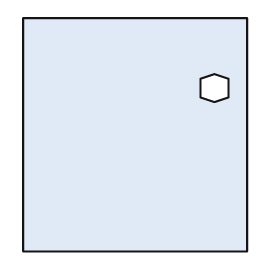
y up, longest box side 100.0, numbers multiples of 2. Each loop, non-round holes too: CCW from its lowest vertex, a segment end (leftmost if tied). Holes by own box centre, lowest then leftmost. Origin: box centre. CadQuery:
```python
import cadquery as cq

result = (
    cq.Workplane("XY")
    .moveTo(-48.0, -50.0)
    .lineTo(48.0, -50.0)
    .lineTo(48.0, 50.0)
    .lineTo(-48.0, 50.0)
    .close()
    .moveTo(34.0, 14.0)
    .lineTo(40.0, 16.0)
    .lineTo(40.0, 24.0)
    .lineTo(34.0, 26.0)
    .lineTo(28.0, 24.0)
    .lineTo(28.0, 16.0)
    .close()
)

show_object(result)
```